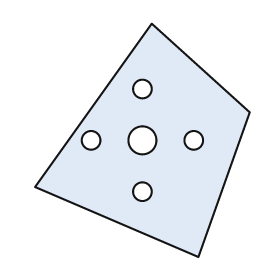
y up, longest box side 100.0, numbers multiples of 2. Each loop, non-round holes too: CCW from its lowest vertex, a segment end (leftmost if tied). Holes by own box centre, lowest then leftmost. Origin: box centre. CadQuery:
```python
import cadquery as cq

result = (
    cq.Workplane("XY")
    .moveTo(24.0, -50.0)
    .lineTo(46.0, 12.0)
    .lineTo(4.0, 50.0)
    .lineTo(-46.0, -20.0)
    .close()
    .moveTo(0.0, -22.0)
    .circle(4.0)
    .moveTo(-22.0, 0.0)
    .circle(4.0)
    .moveTo(0.0, 0.0)
    .circle(6.0)
    .moveTo(22.0, 0.0)
    .circle(4.0)
    .moveTo(0.0, 22.0)
    .circle(4.0)
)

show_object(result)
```